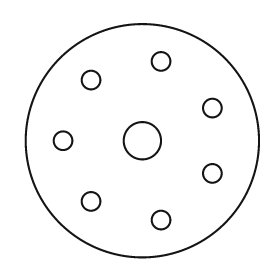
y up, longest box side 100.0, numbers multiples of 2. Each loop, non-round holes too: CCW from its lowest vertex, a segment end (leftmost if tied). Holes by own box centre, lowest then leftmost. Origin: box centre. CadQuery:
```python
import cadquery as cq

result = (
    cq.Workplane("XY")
    .moveTo(0.0, 0.0)
    .circle(50.0)
    .moveTo(8.0, -34.0)
    .circle(4.0)
    .moveTo(-22.0, -26.0)
    .circle(4.0)
    .moveTo(30.0, -14.0)
    .circle(4.0)
    .moveTo(-34.0, 0.0)
    .circle(4.0)
    .moveTo(0.0, 0.0)
    .circle(8.0)
    .moveTo(30.0, 14.0)
    .circle(4.0)
    .moveTo(-22.0, 26.0)
    .circle(4.0)
    .moveTo(8.0, 34.0)
    .circle(4.0)
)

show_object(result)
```